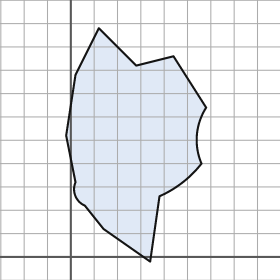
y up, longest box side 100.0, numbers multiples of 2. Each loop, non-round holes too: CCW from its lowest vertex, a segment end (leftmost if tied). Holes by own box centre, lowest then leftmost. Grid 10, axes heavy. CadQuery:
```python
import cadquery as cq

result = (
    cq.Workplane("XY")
    .moveTo(34.0, -2.0)
    .lineTo(38.0, 26.0)
    .threePointArc((48.0, 32.0), (56.0, 40.0))
    .threePointArc((54.0, 52.0), (58.0, 64.0))
    .lineTo(44.0, 86.0)
    .lineTo(28.0, 82.0)
    .lineTo(12.0, 98.0)
    .lineTo(2.0, 78.0)
    .lineTo(-2.0, 52.0)
    .lineTo(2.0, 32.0)
    .threePointArc((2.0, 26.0), (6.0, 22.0))
    .lineTo(14.0, 12.0)
    .close()
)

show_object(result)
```